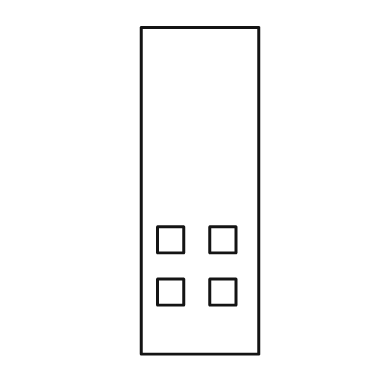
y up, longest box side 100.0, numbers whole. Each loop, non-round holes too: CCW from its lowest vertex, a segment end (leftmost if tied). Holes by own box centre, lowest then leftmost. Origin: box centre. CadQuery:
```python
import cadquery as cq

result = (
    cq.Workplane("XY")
    .moveTo(-18.0, -50.0)
    .lineTo(18.0, -50.0)
    .lineTo(18.0, 50.0)
    .lineTo(-18.0, 50.0)
    .close()
    .moveTo(-13.0, -35.0)
    .lineTo(-5.0, -35.0)
    .lineTo(-5.0, -27.0)
    .lineTo(-13.0, -27.0)
    .close()
    .moveTo(3.0, -35.0)
    .lineTo(11.0, -35.0)
    .lineTo(11.0, -27.0)
    .lineTo(3.0, -27.0)
    .close()
    .moveTo(-13.0, -19.0)
    .lineTo(-5.0, -19.0)
    .lineTo(-5.0, -11.0)
    .lineTo(-13.0, -11.0)
    .close()
    .moveTo(3.0, -19.0)
    .lineTo(11.0, -19.0)
    .lineTo(11.0, -11.0)
    .lineTo(3.0, -11.0)
    .close()
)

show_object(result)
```